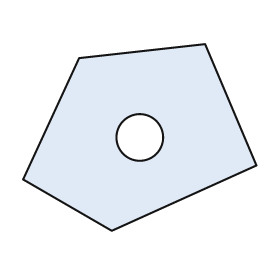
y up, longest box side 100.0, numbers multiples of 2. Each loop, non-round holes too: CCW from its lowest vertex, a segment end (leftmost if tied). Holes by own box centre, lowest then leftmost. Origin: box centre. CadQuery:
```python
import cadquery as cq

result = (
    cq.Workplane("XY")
    .moveTo(-12.0, -40.0)
    .lineTo(50.0, -12.0)
    .lineTo(28.0, 40.0)
    .lineTo(-26.0, 34.0)
    .lineTo(-50.0, -18.0)
    .close()
    .moveTo(0.0, 0.0)
    .circle(10.0)
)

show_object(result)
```